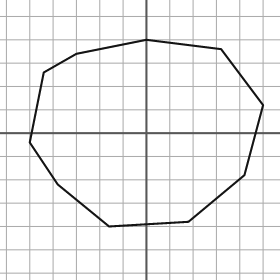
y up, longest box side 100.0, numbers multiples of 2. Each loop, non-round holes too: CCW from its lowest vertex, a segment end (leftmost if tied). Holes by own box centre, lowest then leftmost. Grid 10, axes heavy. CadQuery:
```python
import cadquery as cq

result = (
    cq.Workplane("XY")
    .moveTo(-16.0, -40.0)
    .lineTo(18.0, -38.0)
    .lineTo(42.0, -18.0)
    .lineTo(50.0, 12.0)
    .lineTo(32.0, 36.0)
    .lineTo(0.0, 40.0)
    .lineTo(-30.0, 34.0)
    .lineTo(-44.0, 26.0)
    .lineTo(-50.0, -4.0)
    .lineTo(-38.0, -22.0)
    .close()
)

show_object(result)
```